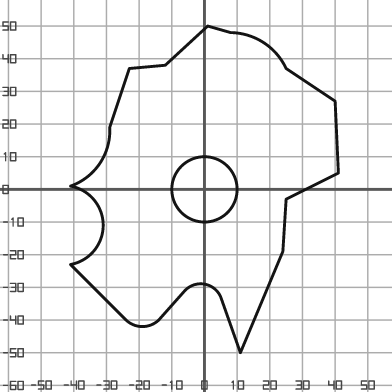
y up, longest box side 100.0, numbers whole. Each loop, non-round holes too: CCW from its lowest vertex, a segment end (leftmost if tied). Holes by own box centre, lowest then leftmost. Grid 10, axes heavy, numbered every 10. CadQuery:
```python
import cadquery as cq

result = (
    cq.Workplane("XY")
    .moveTo(11.0, -50.0)
    .lineTo(24.0, -19.0)
    .lineTo(25.0, -3.0)
    .lineTo(41.0, 5.0)
    .lineTo(40.0, 27.0)
    .lineTo(25.0, 37.0)
    .threePointArc((18.0, 45.0), (8.0, 48.0))
    .lineTo(1.0, 50.0)
    .lineTo(-12.0, 38.0)
    .lineTo(-23.0, 37.0)
    .lineTo(-29.0, 19.0)
    .threePointArc((-32.0, 8.0), (-41.0, 1.0))
    .threePointArc((-31.0, -11.0), (-41.0, -23.0))
    .lineTo(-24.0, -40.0)
    .threePointArc((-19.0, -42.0), (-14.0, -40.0))
    .lineTo(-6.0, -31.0)
    .threePointArc((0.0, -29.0), (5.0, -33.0))
    .close()
    .moveTo(0.0, 0.0)
    .circle(10.0)
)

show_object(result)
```